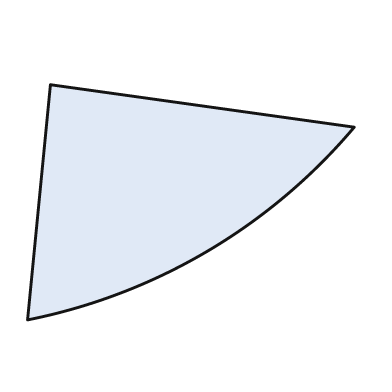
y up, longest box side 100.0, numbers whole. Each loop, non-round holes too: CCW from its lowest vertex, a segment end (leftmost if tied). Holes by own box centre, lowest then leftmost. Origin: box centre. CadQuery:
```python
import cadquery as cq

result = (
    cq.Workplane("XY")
    .moveTo(-50.0, -36.0)
    .threePointArc((5.0, -15.0), (50.0, 23.0))
    .lineTo(-43.0, 36.0)
    .close()
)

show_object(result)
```